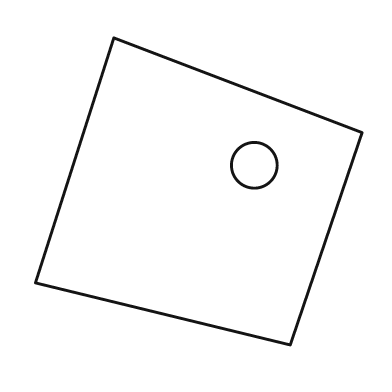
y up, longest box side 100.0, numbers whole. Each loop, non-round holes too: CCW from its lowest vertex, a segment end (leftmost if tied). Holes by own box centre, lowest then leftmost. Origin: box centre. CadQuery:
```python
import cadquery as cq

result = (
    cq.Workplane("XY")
    .moveTo(28.0, -47.0)
    .lineTo(50.0, 18.0)
    .lineTo(-26.0, 47.0)
    .lineTo(-50.0, -28.0)
    .close()
    .moveTo(17.0, 8.0)
    .circle(7.0)
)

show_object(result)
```